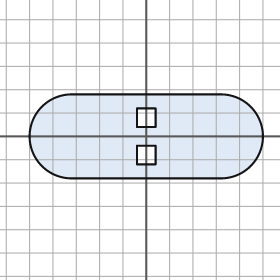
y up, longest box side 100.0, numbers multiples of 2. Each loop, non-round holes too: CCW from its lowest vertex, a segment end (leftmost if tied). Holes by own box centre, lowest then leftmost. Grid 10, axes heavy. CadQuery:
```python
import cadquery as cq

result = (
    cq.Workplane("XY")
    .moveTo(-32.0, -18.0)
    .lineTo(32.0, -18.0)
    .threePointArc((50.0, 0.0), (32.0, 18.0))
    .lineTo(-32.0, 18.0)
    .threePointArc((-50.0, 0.0), (-32.0, -18.0))
    .close()
    .moveTo(-4.0, -12.0)
    .lineTo(4.0, -12.0)
    .lineTo(4.0, -4.0)
    .lineTo(-4.0, -4.0)
    .close()
    .moveTo(-4.0, 4.0)
    .lineTo(4.0, 4.0)
    .lineTo(4.0, 12.0)
    .lineTo(-4.0, 12.0)
    .close()
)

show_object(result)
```